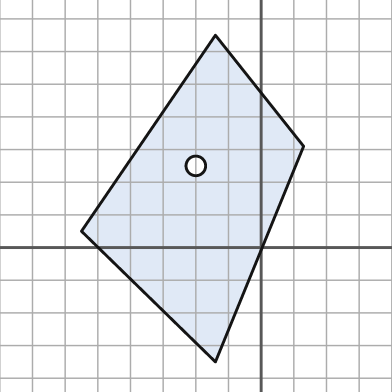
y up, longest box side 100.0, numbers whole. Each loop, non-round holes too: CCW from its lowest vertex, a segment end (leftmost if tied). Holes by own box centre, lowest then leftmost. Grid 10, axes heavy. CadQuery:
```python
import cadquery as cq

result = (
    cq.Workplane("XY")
    .moveTo(-14.0, -35.0)
    .lineTo(13.0, 31.0)
    .lineTo(-14.0, 65.0)
    .lineTo(-55.0, 5.0)
    .close()
    .moveTo(-20.0, 25.0)
    .circle(3.0)
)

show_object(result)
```